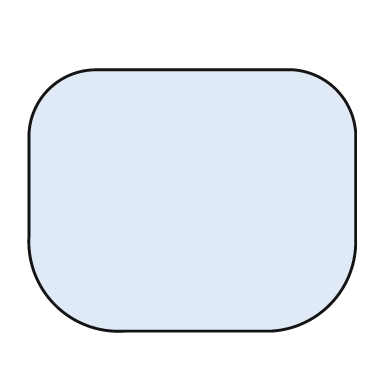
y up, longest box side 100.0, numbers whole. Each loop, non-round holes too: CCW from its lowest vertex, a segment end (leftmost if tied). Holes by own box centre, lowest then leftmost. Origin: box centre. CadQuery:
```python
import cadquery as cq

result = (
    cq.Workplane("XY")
    .moveTo(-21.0, -40.0)
    .lineTo(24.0, -40.0)
    .threePointArc((42.0, -32.0), (50.0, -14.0))
    .lineTo(50.0, 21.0)
    .threePointArc((44.0, 34.0), (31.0, 40.0))
    .lineTo(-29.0, 40.0)
    .threePointArc((-44.0, 34.0), (-50.0, 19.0))
    .lineTo(-50.0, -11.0)
    .threePointArc((-42.0, -32.0), (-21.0, -40.0))
    .close()
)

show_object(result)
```